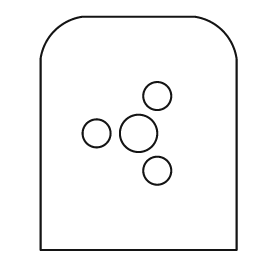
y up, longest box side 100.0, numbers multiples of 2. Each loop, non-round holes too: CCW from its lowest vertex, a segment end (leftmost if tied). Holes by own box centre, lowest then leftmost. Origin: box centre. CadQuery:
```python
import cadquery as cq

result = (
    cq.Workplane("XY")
    .moveTo(-42.0, -50.0)
    .lineTo(42.0, -50.0)
    .lineTo(42.0, 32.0)
    .threePointArc((36.0, 44.0), (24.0, 50.0))
    .lineTo(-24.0, 50.0)
    .threePointArc((-36.0, 44.0), (-42.0, 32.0))
    .close()
    .moveTo(8.0, -16.0)
    .circle(6.0)
    .moveTo(-18.0, 0.0)
    .circle(6.0)
    .moveTo(0.0, 0.0)
    .circle(8.0)
    .moveTo(8.0, 16.0)
    .circle(6.0)
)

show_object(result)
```